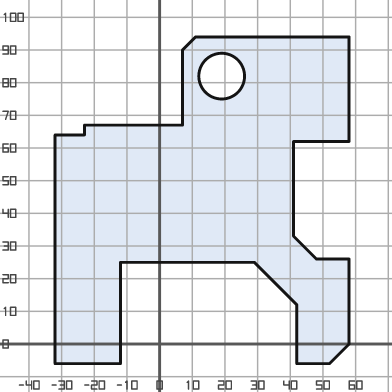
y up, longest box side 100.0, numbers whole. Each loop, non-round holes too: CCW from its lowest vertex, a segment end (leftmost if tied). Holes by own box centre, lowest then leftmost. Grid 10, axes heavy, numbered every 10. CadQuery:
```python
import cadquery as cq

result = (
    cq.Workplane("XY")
    .moveTo(-32.0, -6.0)
    .lineTo(-12.0, -6.0)
    .lineTo(-12.0, 25.0)
    .lineTo(29.0, 25.0)
    .lineTo(42.0, 12.0)
    .lineTo(42.0, -6.0)
    .lineTo(52.0, -6.0)
    .lineTo(58.0, 0.0)
    .lineTo(58.0, 26.0)
    .lineTo(48.0, 26.0)
    .lineTo(41.0, 33.0)
    .lineTo(41.0, 62.0)
    .lineTo(58.0, 62.0)
    .lineTo(58.0, 94.0)
    .lineTo(11.0, 94.0)
    .lineTo(7.0, 90.0)
    .lineTo(7.0, 67.0)
    .lineTo(-23.0, 67.0)
    .lineTo(-23.0, 64.0)
    .lineTo(-32.0, 64.0)
    .close()
    .moveTo(19.0, 82.0)
    .circle(7.0)
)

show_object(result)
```